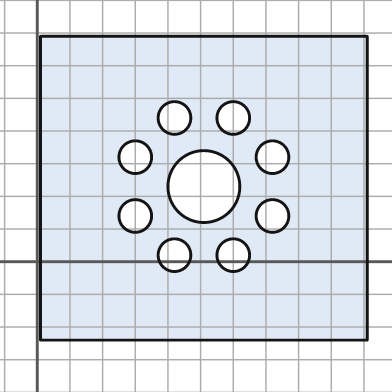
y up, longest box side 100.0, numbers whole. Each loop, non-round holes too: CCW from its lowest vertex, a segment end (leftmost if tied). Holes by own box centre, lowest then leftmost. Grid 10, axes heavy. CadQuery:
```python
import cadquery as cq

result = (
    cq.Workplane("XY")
    .moveTo(1.0, -24.0)
    .lineTo(101.0, -24.0)
    .lineTo(101.0, 69.0)
    .lineTo(1.0, 69.0)
    .close()
    .moveTo(42.0, 2.0)
    .circle(5.0)
    .moveTo(60.0, 2.0)
    .circle(5.0)
    .moveTo(30.0, 14.0)
    .circle(5.0)
    .moveTo(72.0, 14.0)
    .circle(5.0)
    .moveTo(51.0, 23.0)
    .circle(11.0)
    .moveTo(30.0, 32.0)
    .circle(5.0)
    .moveTo(72.0, 32.0)
    .circle(5.0)
    .moveTo(42.0, 44.0)
    .circle(5.0)
    .moveTo(60.0, 44.0)
    .circle(5.0)
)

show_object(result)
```